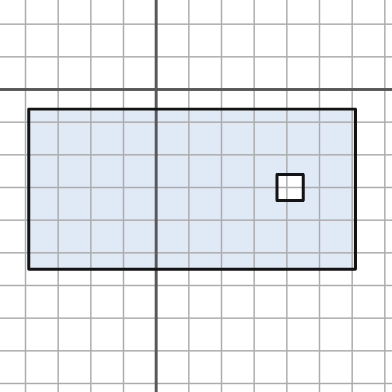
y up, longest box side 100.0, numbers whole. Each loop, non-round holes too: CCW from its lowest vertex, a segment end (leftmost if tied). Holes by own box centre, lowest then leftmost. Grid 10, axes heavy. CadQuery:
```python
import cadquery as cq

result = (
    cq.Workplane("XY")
    .moveTo(-39.0, -55.0)
    .lineTo(61.0, -55.0)
    .lineTo(61.0, -6.0)
    .lineTo(-39.0, -6.0)
    .close()
    .moveTo(37.0, -34.0)
    .lineTo(45.0, -34.0)
    .lineTo(45.0, -26.0)
    .lineTo(37.0, -26.0)
    .close()
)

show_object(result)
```